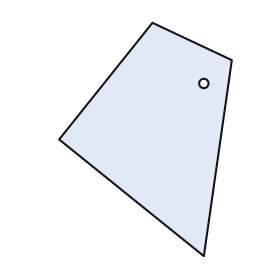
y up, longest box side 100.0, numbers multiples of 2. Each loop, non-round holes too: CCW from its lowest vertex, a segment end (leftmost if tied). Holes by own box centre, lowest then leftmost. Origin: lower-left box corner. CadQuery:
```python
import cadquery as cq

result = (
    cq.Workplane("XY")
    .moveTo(62.0, 0.0)
    .lineTo(74.0, 84.0)
    .lineTo(40.0, 100.0)
    .lineTo(0.0, 50.0)
    .close()
    .moveTo(62.0, 74.0)
    .circle(2.0)
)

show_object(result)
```